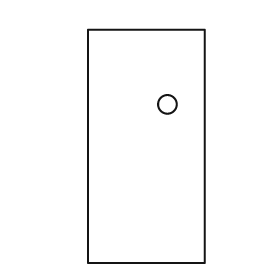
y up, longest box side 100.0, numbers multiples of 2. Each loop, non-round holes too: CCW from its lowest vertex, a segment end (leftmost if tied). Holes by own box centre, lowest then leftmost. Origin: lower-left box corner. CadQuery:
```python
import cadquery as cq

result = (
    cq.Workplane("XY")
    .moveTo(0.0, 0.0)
    .lineTo(50.0, 0.0)
    .lineTo(50.0, 100.0)
    .lineTo(0.0, 100.0)
    .close()
    .moveTo(34.0, 68.0)
    .circle(4.0)
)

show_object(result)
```